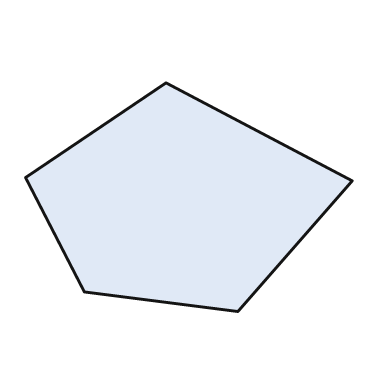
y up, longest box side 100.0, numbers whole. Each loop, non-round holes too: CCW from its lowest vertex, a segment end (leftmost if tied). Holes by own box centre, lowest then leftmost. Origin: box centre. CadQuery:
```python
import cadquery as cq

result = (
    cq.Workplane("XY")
    .moveTo(15.0, -35.0)
    .lineTo(50.0, 5.0)
    .lineTo(-7.0, 35.0)
    .lineTo(-50.0, 6.0)
    .lineTo(-32.0, -29.0)
    .close()
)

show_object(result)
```